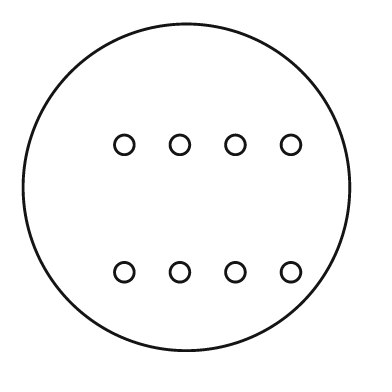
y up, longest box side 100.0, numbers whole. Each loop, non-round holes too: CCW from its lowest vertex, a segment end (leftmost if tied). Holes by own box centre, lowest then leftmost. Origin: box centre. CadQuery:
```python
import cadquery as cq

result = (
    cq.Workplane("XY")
    .moveTo(0.0, 0.0)
    .circle(50.0)
    .moveTo(-19.0, -26.0)
    .circle(3.0)
    .moveTo(-2.0, -26.0)
    .circle(3.0)
    .moveTo(15.0, -26.0)
    .circle(3.0)
    .moveTo(32.0, -26.0)
    .circle(3.0)
    .moveTo(-19.0, 13.0)
    .circle(3.0)
    .moveTo(-2.0, 13.0)
    .circle(3.0)
    .moveTo(15.0, 13.0)
    .circle(3.0)
    .moveTo(32.0, 13.0)
    .circle(3.0)
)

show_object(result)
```